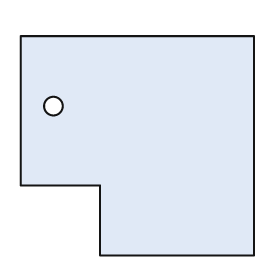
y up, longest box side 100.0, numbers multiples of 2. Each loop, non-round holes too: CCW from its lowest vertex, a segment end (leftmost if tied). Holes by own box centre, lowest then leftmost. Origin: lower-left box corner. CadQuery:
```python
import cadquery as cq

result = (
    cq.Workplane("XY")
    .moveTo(34.0, 0.0)
    .lineTo(100.0, 0.0)
    .lineTo(100.0, 94.0)
    .lineTo(0.0, 94.0)
    .lineTo(0.0, 30.0)
    .lineTo(34.0, 30.0)
    .close()
    .moveTo(14.0, 64.0)
    .circle(4.0)
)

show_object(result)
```